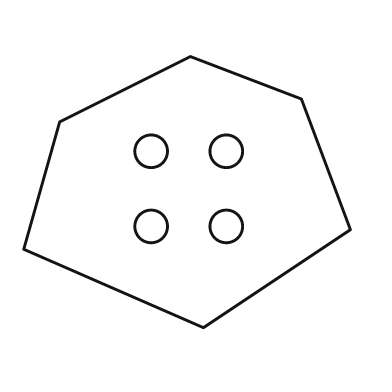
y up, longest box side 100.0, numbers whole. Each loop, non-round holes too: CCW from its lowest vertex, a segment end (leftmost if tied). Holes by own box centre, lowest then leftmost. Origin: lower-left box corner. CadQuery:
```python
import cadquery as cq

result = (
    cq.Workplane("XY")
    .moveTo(55.0, 0.0)
    .lineTo(100.0, 30.0)
    .lineTo(85.0, 70.0)
    .lineTo(51.0, 83.0)
    .lineTo(11.0, 63.0)
    .lineTo(0.0, 24.0)
    .close()
    .moveTo(39.0, 31.0)
    .circle(5.0)
    .moveTo(62.0, 31.0)
    .circle(5.0)
    .moveTo(39.0, 54.0)
    .circle(5.0)
    .moveTo(62.0, 54.0)
    .circle(5.0)
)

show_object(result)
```